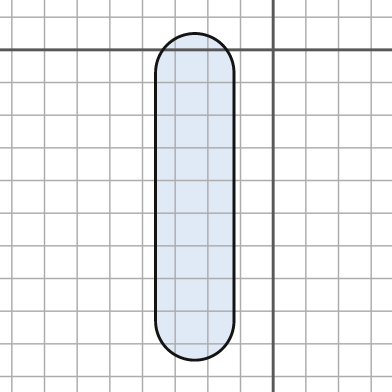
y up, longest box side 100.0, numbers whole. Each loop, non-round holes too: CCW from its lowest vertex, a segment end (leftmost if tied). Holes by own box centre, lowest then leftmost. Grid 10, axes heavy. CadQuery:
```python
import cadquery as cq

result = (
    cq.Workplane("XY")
    .moveTo(-36.0, -83.0)
    .threePointArc((-24.0, -95.0), (-12.0, -83.0))
    .lineTo(-12.0, -7.0)
    .threePointArc((-24.0, 5.0), (-36.0, -7.0))
    .close()
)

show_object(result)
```